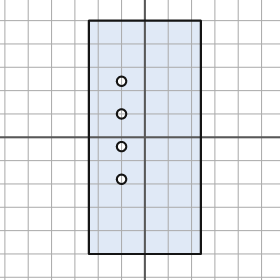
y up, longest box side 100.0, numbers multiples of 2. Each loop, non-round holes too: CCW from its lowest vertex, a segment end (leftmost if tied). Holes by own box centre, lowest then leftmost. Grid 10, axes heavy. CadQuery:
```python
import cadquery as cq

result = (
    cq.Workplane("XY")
    .moveTo(-24.0, -50.0)
    .lineTo(24.0, -50.0)
    .lineTo(24.0, 50.0)
    .lineTo(-24.0, 50.0)
    .close()
    .moveTo(-10.0, -18.0)
    .circle(2.0)
    .moveTo(-10.0, -4.0)
    .circle(2.0)
    .moveTo(-10.0, 10.0)
    .circle(2.0)
    .moveTo(-10.0, 24.0)
    .circle(2.0)
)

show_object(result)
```